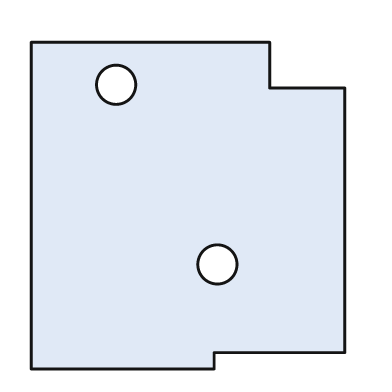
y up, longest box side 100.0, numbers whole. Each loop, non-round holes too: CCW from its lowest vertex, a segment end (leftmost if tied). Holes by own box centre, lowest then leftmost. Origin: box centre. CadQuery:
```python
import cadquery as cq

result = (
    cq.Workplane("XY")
    .moveTo(-48.0, -50.0)
    .lineTo(8.0, -50.0)
    .lineTo(8.0, -45.0)
    .lineTo(48.0, -45.0)
    .lineTo(48.0, 36.0)
    .lineTo(25.0, 36.0)
    .lineTo(25.0, 50.0)
    .lineTo(-48.0, 50.0)
    .close()
    .moveTo(9.0, -18.0)
    .circle(6.0)
    .moveTo(-22.0, 37.0)
    .circle(6.0)
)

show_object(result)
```